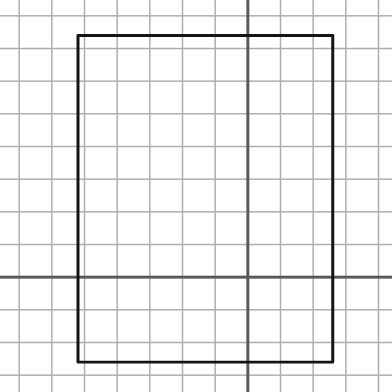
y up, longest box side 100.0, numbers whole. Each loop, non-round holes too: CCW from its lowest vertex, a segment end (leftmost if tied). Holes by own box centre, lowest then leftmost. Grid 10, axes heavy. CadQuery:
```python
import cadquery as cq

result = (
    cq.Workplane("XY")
    .moveTo(-52.0, -26.0)
    .lineTo(26.0, -26.0)
    .lineTo(26.0, 74.0)
    .lineTo(-52.0, 74.0)
    .close()
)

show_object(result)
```